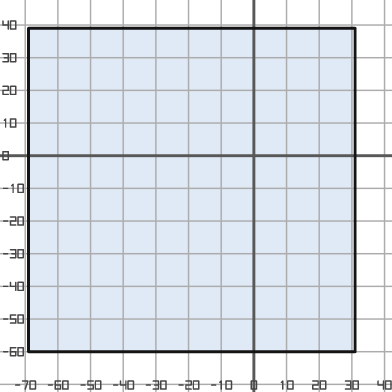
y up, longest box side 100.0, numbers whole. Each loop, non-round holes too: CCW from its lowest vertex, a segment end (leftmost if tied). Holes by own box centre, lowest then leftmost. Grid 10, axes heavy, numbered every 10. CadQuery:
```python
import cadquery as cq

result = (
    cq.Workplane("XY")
    .moveTo(-69.0, -60.0)
    .lineTo(31.0, -60.0)
    .lineTo(31.0, 39.0)
    .lineTo(-69.0, 39.0)
    .close()
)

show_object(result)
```